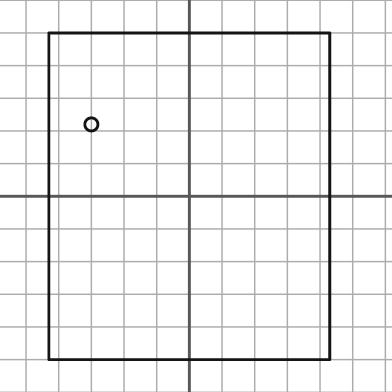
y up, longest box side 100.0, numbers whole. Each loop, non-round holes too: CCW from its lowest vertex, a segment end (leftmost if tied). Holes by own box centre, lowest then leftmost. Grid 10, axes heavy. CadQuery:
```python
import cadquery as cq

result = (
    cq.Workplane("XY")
    .moveTo(-43.0, -50.0)
    .lineTo(43.0, -50.0)
    .lineTo(43.0, 50.0)
    .lineTo(-43.0, 50.0)
    .close()
    .moveTo(-30.0, 22.0)
    .circle(2.0)
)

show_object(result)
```